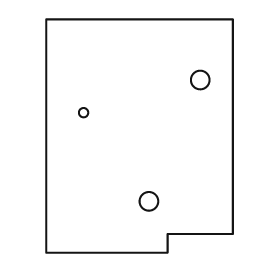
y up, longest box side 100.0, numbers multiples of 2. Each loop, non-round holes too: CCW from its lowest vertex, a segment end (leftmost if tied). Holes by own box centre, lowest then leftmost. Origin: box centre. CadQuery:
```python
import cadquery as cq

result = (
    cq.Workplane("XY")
    .moveTo(-40.0, -50.0)
    .lineTo(12.0, -50.0)
    .lineTo(12.0, -42.0)
    .lineTo(40.0, -42.0)
    .lineTo(40.0, 50.0)
    .lineTo(-40.0, 50.0)
    .close()
    .moveTo(4.0, -28.0)
    .circle(4.0)
    .moveTo(-24.0, 10.0)
    .circle(2.0)
    .moveTo(26.0, 24.0)
    .circle(4.0)
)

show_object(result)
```